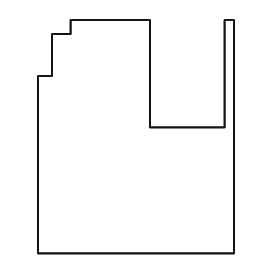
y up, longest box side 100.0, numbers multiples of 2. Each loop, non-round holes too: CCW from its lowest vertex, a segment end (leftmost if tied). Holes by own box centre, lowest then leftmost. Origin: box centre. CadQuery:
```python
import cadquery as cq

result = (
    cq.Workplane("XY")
    .moveTo(-42.0, -50.0)
    .lineTo(42.0, -50.0)
    .lineTo(42.0, 50.0)
    .lineTo(38.0, 50.0)
    .lineTo(38.0, 4.0)
    .lineTo(6.0, 4.0)
    .lineTo(6.0, 50.0)
    .lineTo(-28.0, 50.0)
    .lineTo(-28.0, 44.0)
    .lineTo(-36.0, 44.0)
    .lineTo(-36.0, 26.0)
    .lineTo(-42.0, 26.0)
    .close()
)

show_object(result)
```